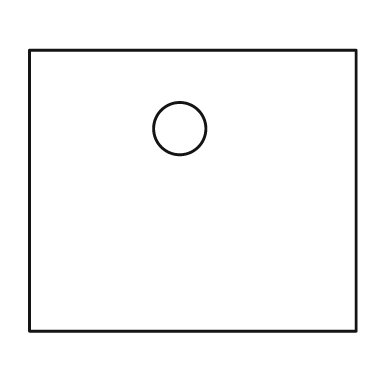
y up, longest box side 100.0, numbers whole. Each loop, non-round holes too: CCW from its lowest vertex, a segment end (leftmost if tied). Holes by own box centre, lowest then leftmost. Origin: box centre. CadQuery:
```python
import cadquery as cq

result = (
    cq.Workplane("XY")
    .moveTo(-50.0, -43.0)
    .lineTo(50.0, -43.0)
    .lineTo(50.0, 43.0)
    .lineTo(-50.0, 43.0)
    .close()
    .moveTo(-4.0, 19.0)
    .circle(8.0)
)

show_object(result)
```